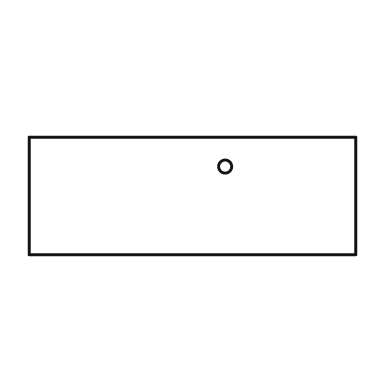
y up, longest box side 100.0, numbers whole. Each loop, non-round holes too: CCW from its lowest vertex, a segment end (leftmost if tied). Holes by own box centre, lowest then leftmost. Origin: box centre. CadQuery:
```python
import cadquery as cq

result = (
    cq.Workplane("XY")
    .moveTo(-50.0, -18.0)
    .lineTo(50.0, -18.0)
    .lineTo(50.0, 18.0)
    .lineTo(-50.0, 18.0)
    .close()
    .moveTo(10.0, 9.0)
    .circle(2.0)
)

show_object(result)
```